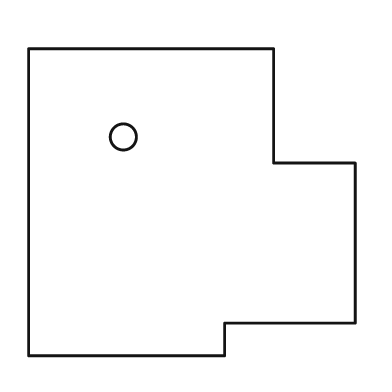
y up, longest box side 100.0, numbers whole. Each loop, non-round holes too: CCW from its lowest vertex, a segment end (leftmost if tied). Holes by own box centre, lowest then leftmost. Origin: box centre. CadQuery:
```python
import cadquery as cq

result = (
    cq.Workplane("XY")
    .moveTo(-50.0, -47.0)
    .lineTo(10.0, -47.0)
    .lineTo(10.0, -37.0)
    .lineTo(50.0, -37.0)
    .lineTo(50.0, 12.0)
    .lineTo(25.0, 12.0)
    .lineTo(25.0, 47.0)
    .lineTo(-50.0, 47.0)
    .close()
    .moveTo(-21.0, 20.0)
    .circle(4.0)
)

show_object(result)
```